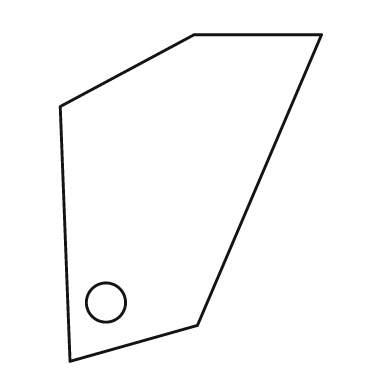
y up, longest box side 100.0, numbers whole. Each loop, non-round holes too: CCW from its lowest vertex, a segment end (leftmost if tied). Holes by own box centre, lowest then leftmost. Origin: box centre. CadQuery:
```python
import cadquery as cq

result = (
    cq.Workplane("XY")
    .moveTo(-37.0, -50.0)
    .lineTo(2.0, -39.0)
    .lineTo(40.0, 50.0)
    .lineTo(1.0, 50.0)
    .lineTo(-40.0, 28.0)
    .close()
    .moveTo(-26.0, -32.0)
    .circle(6.0)
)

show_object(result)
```